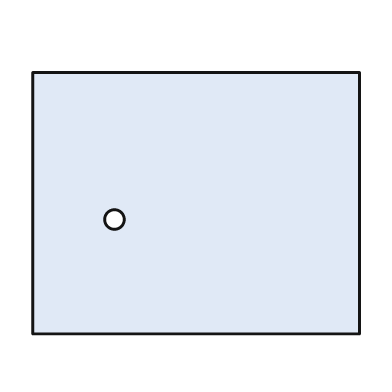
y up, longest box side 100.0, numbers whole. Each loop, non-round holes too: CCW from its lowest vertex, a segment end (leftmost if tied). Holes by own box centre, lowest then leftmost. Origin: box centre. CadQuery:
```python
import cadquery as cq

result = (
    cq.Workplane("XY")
    .moveTo(-50.0, -40.0)
    .lineTo(50.0, -40.0)
    .lineTo(50.0, 40.0)
    .lineTo(-50.0, 40.0)
    .close()
    .moveTo(-25.0, -5.0)
    .circle(3.0)
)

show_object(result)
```